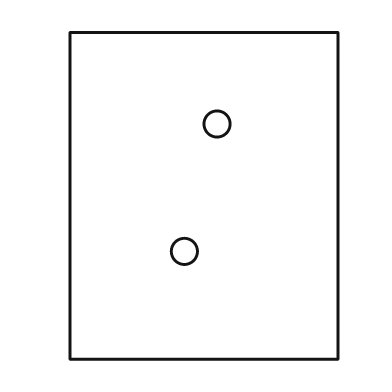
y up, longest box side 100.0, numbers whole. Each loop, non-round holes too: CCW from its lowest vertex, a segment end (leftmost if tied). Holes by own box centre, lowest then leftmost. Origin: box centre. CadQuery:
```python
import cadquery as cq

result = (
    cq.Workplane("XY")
    .moveTo(-41.0, -50.0)
    .lineTo(41.0, -50.0)
    .lineTo(41.0, 50.0)
    .lineTo(-41.0, 50.0)
    .close()
    .moveTo(-6.0, -17.0)
    .circle(4.0)
    .moveTo(4.0, 22.0)
    .circle(4.0)
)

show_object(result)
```